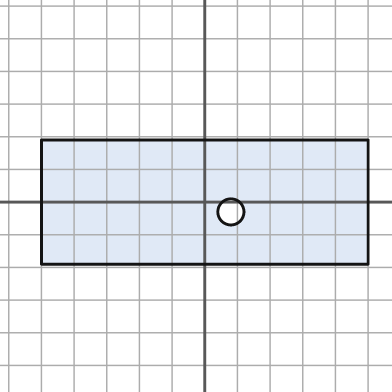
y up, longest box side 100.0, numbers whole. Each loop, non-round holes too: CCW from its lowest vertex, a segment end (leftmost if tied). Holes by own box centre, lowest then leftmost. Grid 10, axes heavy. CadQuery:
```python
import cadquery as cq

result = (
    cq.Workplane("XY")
    .moveTo(-50.0, -19.0)
    .lineTo(50.0, -19.0)
    .lineTo(50.0, 19.0)
    .lineTo(-50.0, 19.0)
    .close()
    .moveTo(8.0, -3.0)
    .circle(4.0)
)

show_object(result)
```